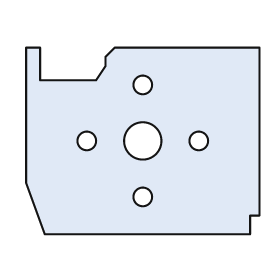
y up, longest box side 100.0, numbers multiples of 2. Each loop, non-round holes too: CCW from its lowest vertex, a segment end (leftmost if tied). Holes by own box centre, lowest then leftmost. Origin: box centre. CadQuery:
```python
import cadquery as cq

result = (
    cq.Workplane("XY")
    .moveTo(-42.0, -40.0)
    .lineTo(46.0, -40.0)
    .lineTo(46.0, -32.0)
    .lineTo(50.0, -32.0)
    .lineTo(50.0, 40.0)
    .lineTo(-12.0, 40.0)
    .lineTo(-16.0, 36.0)
    .lineTo(-16.0, 32.0)
    .lineTo(-20.0, 26.0)
    .lineTo(-44.0, 26.0)
    .lineTo(-44.0, 40.0)
    .lineTo(-50.0, 40.0)
    .lineTo(-50.0, -18.0)
    .close()
    .moveTo(0.0, -24.0)
    .circle(4.0)
    .moveTo(-24.0, 0.0)
    .circle(4.0)
    .moveTo(0.0, 0.0)
    .circle(8.0)
    .moveTo(24.0, 0.0)
    .circle(4.0)
    .moveTo(0.0, 24.0)
    .circle(4.0)
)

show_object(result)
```